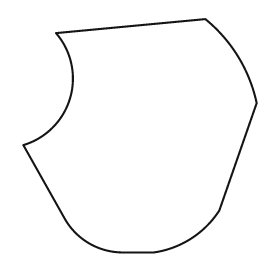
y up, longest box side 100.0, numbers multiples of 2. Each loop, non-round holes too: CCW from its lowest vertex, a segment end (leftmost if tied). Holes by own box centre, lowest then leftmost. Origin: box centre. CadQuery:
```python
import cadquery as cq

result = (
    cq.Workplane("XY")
    .moveTo(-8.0, -50.0)
    .lineTo(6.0, -50.0)
    .threePointArc((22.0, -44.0), (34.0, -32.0))
    .lineTo(50.0, 14.0)
    .threePointArc((42.0, 34.0), (28.0, 50.0))
    .lineTo(-36.0, 44.0)
    .threePointArc((-30.0, 16.0), (-50.0, -4.0))
    .lineTo(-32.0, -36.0)
    .threePointArc((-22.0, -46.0), (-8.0, -50.0))
    .close()
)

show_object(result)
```